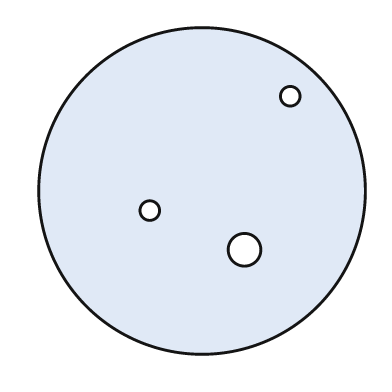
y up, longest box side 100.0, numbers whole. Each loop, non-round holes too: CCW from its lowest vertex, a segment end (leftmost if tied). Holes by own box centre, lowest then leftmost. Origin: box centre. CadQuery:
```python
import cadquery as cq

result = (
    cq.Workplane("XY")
    .moveTo(0.0, 0.0)
    .circle(50.0)
    .moveTo(13.0, -18.0)
    .circle(5.0)
    .moveTo(-16.0, -6.0)
    .circle(3.0)
    .moveTo(27.0, 29.0)
    .circle(3.0)
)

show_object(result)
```